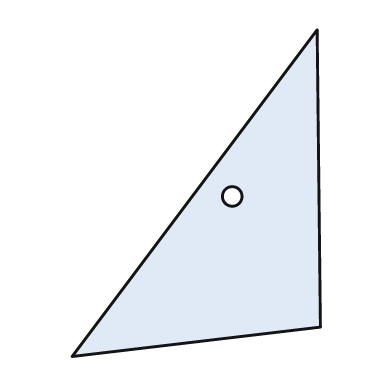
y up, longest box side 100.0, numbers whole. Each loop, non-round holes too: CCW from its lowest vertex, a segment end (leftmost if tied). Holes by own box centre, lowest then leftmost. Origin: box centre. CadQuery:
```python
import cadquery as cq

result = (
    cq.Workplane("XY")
    .moveTo(-38.0, -50.0)
    .lineTo(38.0, -41.0)
    .lineTo(37.0, 50.0)
    .close()
    .moveTo(11.0, -1.0)
    .circle(3.0)
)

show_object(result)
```